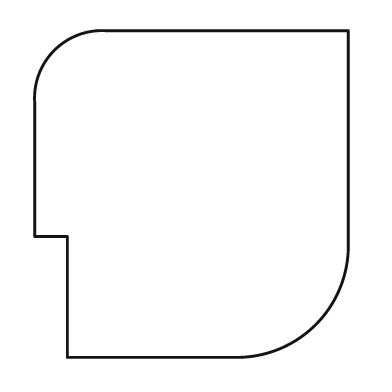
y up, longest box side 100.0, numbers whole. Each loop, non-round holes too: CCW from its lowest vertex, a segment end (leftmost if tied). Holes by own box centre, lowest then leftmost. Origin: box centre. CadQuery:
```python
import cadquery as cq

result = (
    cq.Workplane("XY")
    .moveTo(-38.0, -50.0)
    .lineTo(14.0, -50.0)
    .threePointArc((38.0, -40.0), (48.0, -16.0))
    .lineTo(48.0, 50.0)
    .lineTo(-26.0, 50.0)
    .threePointArc((-42.0, 44.0), (-48.0, 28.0))
    .lineTo(-48.0, -13.0)
    .lineTo(-38.0, -13.0)
    .close()
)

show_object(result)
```